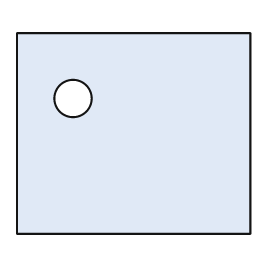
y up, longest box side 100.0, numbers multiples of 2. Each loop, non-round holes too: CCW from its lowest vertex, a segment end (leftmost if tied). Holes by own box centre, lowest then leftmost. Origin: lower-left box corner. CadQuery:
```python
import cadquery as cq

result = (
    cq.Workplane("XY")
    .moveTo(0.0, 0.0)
    .lineTo(100.0, 0.0)
    .lineTo(100.0, 86.0)
    .lineTo(0.0, 86.0)
    .close()
    .moveTo(24.0, 58.0)
    .circle(8.0)
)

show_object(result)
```